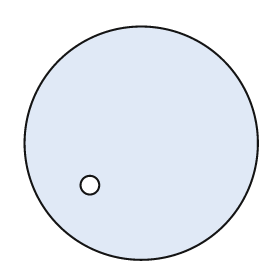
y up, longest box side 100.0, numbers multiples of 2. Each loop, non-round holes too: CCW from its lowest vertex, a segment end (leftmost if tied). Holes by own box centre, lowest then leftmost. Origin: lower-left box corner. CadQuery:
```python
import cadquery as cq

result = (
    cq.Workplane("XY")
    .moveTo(50.0, 50.0)
    .circle(50.0)
    .moveTo(28.0, 32.0)
    .circle(4.0)
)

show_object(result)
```